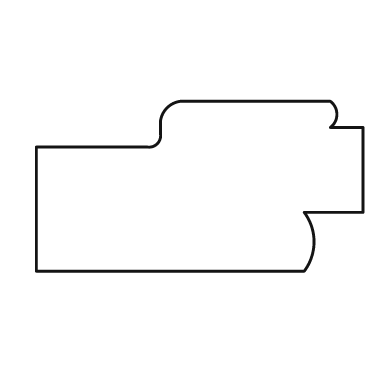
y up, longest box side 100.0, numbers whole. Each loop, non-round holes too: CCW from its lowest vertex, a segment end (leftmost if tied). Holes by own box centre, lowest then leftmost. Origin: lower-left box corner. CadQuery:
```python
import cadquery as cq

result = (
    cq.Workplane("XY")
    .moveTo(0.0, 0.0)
    .lineTo(82.0, 0.0)
    .threePointArc((85.0, 9.0), (82.0, 18.0))
    .lineTo(100.0, 18.0)
    .lineTo(100.0, 44.0)
    .lineTo(90.0, 44.0)
    .threePointArc((92.0, 48.0), (90.0, 52.0))
    .lineTo(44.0, 52.0)
    .threePointArc((40.0, 50.0), (38.0, 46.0))
    .lineTo(38.0, 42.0)
    .threePointArc((37.0, 39.0), (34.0, 38.0))
    .lineTo(0.0, 38.0)
    .close()
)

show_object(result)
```